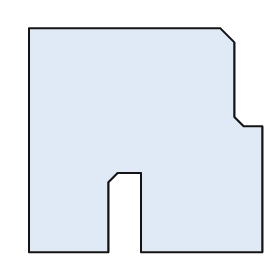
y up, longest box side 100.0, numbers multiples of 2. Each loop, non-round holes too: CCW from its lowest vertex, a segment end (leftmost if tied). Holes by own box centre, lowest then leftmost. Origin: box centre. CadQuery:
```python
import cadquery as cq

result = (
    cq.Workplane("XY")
    .moveTo(-50.0, -48.0)
    .lineTo(-16.0, -48.0)
    .lineTo(-16.0, -18.0)
    .lineTo(-12.0, -14.0)
    .lineTo(-2.0, -14.0)
    .lineTo(-2.0, -48.0)
    .lineTo(50.0, -48.0)
    .lineTo(50.0, 6.0)
    .lineTo(42.0, 6.0)
    .lineTo(38.0, 10.0)
    .lineTo(38.0, 42.0)
    .lineTo(32.0, 48.0)
    .lineTo(-50.0, 48.0)
    .close()
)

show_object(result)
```